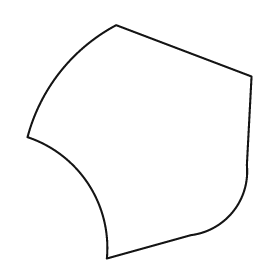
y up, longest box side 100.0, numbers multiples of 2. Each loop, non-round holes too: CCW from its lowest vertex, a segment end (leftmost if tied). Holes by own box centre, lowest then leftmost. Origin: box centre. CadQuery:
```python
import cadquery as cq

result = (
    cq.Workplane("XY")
    .moveTo(-14.0, -50.0)
    .lineTo(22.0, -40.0)
    .threePointArc((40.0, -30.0), (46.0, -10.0))
    .lineTo(48.0, 28.0)
    .lineTo(-10.0, 50.0)
    .threePointArc((-34.0, 30.0), (-48.0, 2.0))
    .threePointArc((-22.0, -18.0), (-14.0, -50.0))
    .close()
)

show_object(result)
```